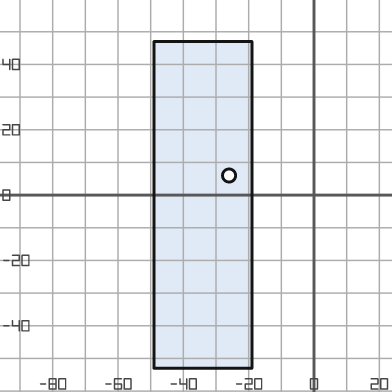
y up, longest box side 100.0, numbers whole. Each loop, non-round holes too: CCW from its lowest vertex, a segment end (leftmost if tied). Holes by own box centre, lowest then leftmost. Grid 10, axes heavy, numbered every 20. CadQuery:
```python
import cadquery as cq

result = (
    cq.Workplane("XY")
    .moveTo(-49.0, -53.0)
    .lineTo(-19.0, -53.0)
    .lineTo(-19.0, 47.0)
    .lineTo(-49.0, 47.0)
    .close()
    .moveTo(-26.0, 6.0)
    .circle(2.0)
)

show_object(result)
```